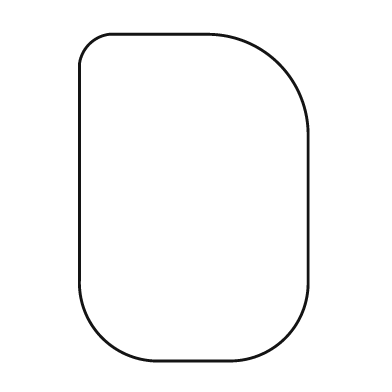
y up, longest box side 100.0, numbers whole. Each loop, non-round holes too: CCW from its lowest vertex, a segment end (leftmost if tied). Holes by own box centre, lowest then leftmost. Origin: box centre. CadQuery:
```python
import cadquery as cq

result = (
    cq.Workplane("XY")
    .moveTo(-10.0, -50.0)
    .lineTo(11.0, -50.0)
    .threePointArc((28.0, -43.0), (35.0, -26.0))
    .lineTo(35.0, 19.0)
    .threePointArc((26.0, 41.0), (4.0, 50.0))
    .lineTo(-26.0, 50.0)
    .threePointArc((-32.0, 47.0), (-35.0, 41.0))
    .lineTo(-35.0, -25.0)
    .threePointArc((-28.0, -43.0), (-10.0, -50.0))
    .close()
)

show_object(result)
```